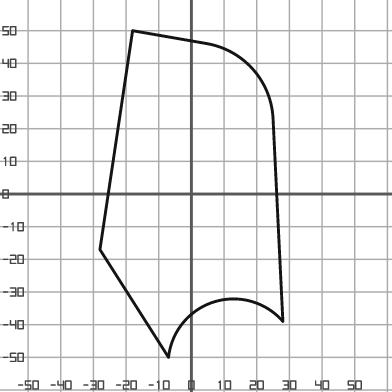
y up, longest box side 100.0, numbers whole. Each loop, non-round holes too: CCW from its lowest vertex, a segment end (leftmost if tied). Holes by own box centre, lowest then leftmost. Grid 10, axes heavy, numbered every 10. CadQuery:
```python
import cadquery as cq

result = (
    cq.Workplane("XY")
    .moveTo(-7.0, -50.0)
    .threePointArc((7.0, -33.0), (28.0, -39.0))
    .lineTo(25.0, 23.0)
    .threePointArc((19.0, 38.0), (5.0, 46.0))
    .lineTo(-18.0, 50.0)
    .lineTo(-28.0, -17.0)
    .close()
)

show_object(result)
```